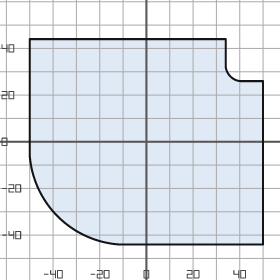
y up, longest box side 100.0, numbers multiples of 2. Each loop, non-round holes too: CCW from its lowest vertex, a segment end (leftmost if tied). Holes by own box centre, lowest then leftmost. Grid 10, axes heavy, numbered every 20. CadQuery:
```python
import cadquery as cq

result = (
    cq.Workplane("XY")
    .moveTo(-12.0, -44.0)
    .lineTo(50.0, -44.0)
    .lineTo(50.0, 26.0)
    .lineTo(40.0, 26.0)
    .threePointArc((36.0, 28.0), (34.0, 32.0))
    .lineTo(34.0, 44.0)
    .lineTo(-50.0, 44.0)
    .lineTo(-50.0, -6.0)
    .threePointArc((-38.0, -32.0), (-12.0, -44.0))
    .close()
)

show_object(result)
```